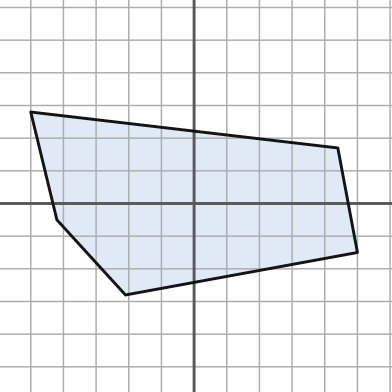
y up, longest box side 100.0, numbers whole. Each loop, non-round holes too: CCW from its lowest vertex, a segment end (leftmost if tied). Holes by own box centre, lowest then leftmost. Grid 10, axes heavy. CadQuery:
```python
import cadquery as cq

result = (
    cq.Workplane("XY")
    .moveTo(-21.0, -28.0)
    .lineTo(50.0, -15.0)
    .lineTo(44.0, 17.0)
    .lineTo(-50.0, 28.0)
    .lineTo(-42.0, -5.0)
    .close()
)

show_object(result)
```